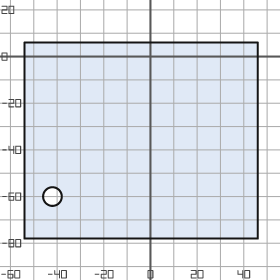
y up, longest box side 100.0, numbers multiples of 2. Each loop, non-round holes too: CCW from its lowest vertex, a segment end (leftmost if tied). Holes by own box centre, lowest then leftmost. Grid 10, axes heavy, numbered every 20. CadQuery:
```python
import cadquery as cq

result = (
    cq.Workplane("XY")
    .moveTo(-54.0, -78.0)
    .lineTo(46.0, -78.0)
    .lineTo(46.0, 6.0)
    .lineTo(-54.0, 6.0)
    .close()
    .moveTo(-42.0, -60.0)
    .circle(4.0)
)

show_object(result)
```